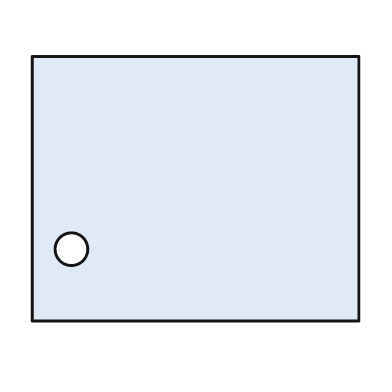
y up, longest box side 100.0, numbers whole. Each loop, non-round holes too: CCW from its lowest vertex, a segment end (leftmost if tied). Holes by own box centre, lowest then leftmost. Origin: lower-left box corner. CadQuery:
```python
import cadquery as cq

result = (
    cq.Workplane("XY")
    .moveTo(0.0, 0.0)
    .lineTo(100.0, 0.0)
    .lineTo(100.0, 81.0)
    .lineTo(0.0, 81.0)
    .close()
    .moveTo(12.0, 22.0)
    .circle(5.0)
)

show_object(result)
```